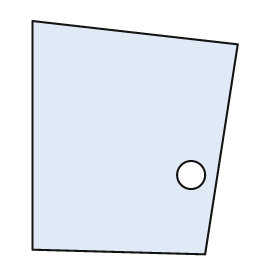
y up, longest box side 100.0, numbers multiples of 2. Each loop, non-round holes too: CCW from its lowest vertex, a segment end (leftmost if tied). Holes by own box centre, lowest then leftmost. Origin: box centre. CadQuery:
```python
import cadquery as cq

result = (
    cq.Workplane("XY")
    .moveTo(30.0, -50.0)
    .lineTo(44.0, 40.0)
    .lineTo(-44.0, 50.0)
    .lineTo(-44.0, -48.0)
    .close()
    .moveTo(24.0, -16.0)
    .circle(6.0)
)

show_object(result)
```